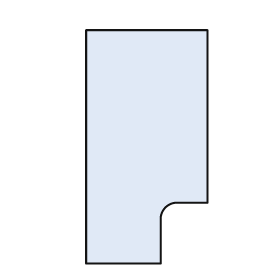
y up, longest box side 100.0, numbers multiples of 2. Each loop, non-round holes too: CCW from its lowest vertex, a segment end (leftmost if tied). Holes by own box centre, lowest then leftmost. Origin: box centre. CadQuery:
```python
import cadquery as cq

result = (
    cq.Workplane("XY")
    .moveTo(-26.0, -50.0)
    .lineTo(6.0, -50.0)
    .lineTo(6.0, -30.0)
    .threePointArc((8.0, -26.0), (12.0, -24.0))
    .lineTo(26.0, -24.0)
    .lineTo(26.0, 50.0)
    .lineTo(-26.0, 50.0)
    .close()
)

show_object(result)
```